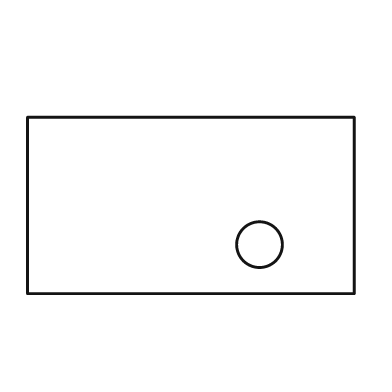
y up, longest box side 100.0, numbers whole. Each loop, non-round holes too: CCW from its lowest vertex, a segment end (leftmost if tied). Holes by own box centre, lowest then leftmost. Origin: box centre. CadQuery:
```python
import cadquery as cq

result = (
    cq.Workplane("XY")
    .moveTo(-50.0, -27.0)
    .lineTo(50.0, -27.0)
    .lineTo(50.0, 27.0)
    .lineTo(-50.0, 27.0)
    .close()
    .moveTo(21.0, -12.0)
    .circle(7.0)
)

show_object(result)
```